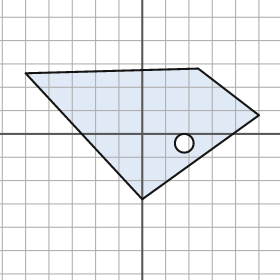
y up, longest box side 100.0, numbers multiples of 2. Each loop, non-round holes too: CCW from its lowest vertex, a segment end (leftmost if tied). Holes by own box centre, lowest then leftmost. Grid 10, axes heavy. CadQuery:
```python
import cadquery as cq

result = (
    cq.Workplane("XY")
    .moveTo(0.0, -28.0)
    .lineTo(50.0, 8.0)
    .lineTo(24.0, 28.0)
    .lineTo(-50.0, 26.0)
    .close()
    .moveTo(18.0, -4.0)
    .circle(4.0)
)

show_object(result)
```